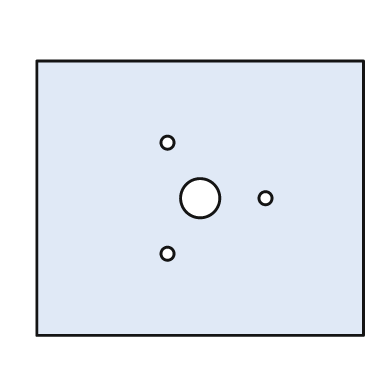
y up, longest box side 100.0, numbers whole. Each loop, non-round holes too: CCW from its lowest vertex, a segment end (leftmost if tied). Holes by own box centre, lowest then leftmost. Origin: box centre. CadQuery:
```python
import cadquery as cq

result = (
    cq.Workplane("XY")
    .moveTo(-50.0, -42.0)
    .lineTo(50.0, -42.0)
    .lineTo(50.0, 42.0)
    .lineTo(-50.0, 42.0)
    .close()
    .moveTo(-10.0, -17.0)
    .circle(2.0)
    .moveTo(0.0, 0.0)
    .circle(6.0)
    .moveTo(20.0, 0.0)
    .circle(2.0)
    .moveTo(-10.0, 17.0)
    .circle(2.0)
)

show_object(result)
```